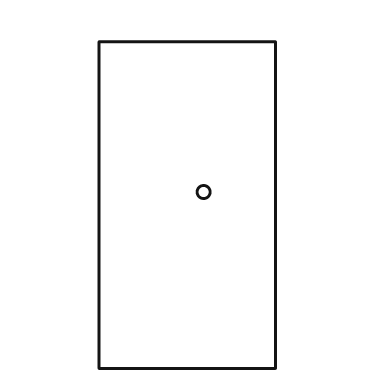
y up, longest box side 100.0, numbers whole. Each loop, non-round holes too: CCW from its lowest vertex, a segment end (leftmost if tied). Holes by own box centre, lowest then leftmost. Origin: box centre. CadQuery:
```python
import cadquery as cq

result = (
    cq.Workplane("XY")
    .moveTo(-27.0, -50.0)
    .lineTo(27.0, -50.0)
    .lineTo(27.0, 50.0)
    .lineTo(-27.0, 50.0)
    .close()
    .moveTo(5.0, 4.0)
    .circle(2.0)
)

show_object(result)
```